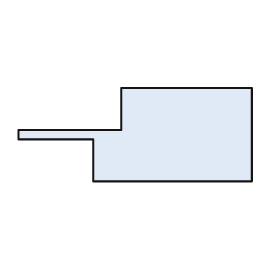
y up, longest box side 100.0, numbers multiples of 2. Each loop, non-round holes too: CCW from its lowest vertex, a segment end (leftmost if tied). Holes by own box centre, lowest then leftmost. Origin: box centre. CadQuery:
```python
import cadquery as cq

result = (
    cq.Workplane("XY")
    .moveTo(-18.0, -20.0)
    .lineTo(50.0, -20.0)
    .lineTo(50.0, 20.0)
    .lineTo(-6.0, 20.0)
    .lineTo(-6.0, 2.0)
    .lineTo(-50.0, 2.0)
    .lineTo(-50.0, -2.0)
    .lineTo(-18.0, -2.0)
    .close()
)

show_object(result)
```